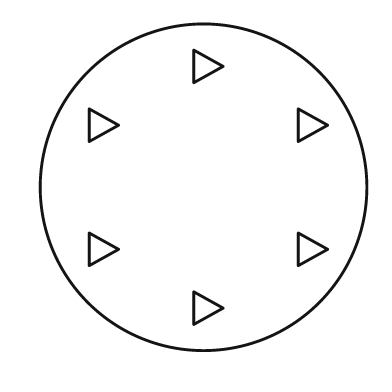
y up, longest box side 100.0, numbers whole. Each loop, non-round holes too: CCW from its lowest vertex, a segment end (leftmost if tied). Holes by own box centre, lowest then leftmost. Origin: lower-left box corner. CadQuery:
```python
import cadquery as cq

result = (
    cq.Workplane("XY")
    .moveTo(50.0, 50.0)
    .circle(50.0)
    .moveTo(47.0, 8.0)
    .lineTo(56.0, 13.0)
    .lineTo(47.0, 18.0)
    .close()
    .moveTo(15.0, 26.0)
    .lineTo(24.0, 31.0)
    .lineTo(15.0, 36.0)
    .close()
    .moveTo(79.0, 26.0)
    .lineTo(88.0, 31.0)
    .lineTo(79.0, 36.0)
    .close()
    .moveTo(15.0, 64.0)
    .lineTo(24.0, 69.0)
    .lineTo(15.0, 74.0)
    .close()
    .moveTo(79.0, 64.0)
    .lineTo(88.0, 69.0)
    .lineTo(79.0, 74.0)
    .close()
    .moveTo(47.0, 82.0)
    .lineTo(56.0, 87.0)
    .lineTo(47.0, 92.0)
    .close()
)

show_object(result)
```